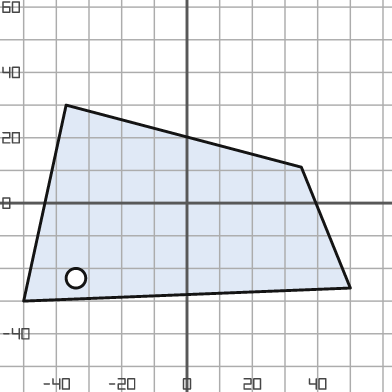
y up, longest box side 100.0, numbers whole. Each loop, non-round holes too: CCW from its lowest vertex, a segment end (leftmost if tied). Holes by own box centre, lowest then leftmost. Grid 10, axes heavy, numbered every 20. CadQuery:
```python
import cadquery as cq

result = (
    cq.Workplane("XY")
    .moveTo(-50.0, -30.0)
    .lineTo(50.0, -26.0)
    .lineTo(35.0, 11.0)
    .lineTo(-37.0, 30.0)
    .close()
    .moveTo(-34.0, -23.0)
    .circle(3.0)
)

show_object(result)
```